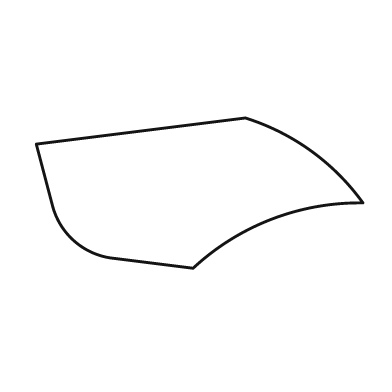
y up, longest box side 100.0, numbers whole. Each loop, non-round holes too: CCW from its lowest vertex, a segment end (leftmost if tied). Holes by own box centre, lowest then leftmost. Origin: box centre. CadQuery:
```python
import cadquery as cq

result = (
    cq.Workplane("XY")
    .moveTo(-2.0, -23.0)
    .threePointArc((22.0, -8.0), (50.0, -3.0))
    .threePointArc((34.0, 13.0), (14.0, 23.0))
    .lineTo(-50.0, 15.0)
    .lineTo(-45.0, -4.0)
    .threePointArc((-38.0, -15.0), (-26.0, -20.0))
    .close()
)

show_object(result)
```